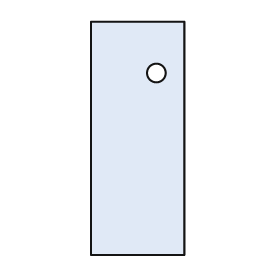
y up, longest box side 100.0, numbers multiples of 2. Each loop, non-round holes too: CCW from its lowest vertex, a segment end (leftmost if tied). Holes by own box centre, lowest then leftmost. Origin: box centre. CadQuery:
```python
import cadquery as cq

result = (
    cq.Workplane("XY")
    .moveTo(-20.0, -50.0)
    .lineTo(20.0, -50.0)
    .lineTo(20.0, 50.0)
    .lineTo(-20.0, 50.0)
    .close()
    .moveTo(8.0, 28.0)
    .circle(4.0)
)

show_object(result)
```